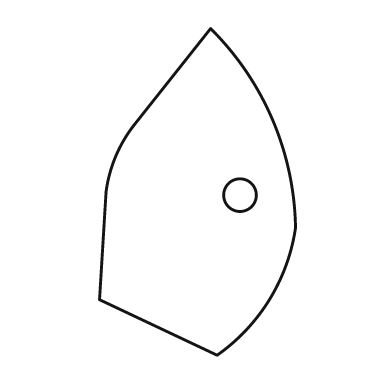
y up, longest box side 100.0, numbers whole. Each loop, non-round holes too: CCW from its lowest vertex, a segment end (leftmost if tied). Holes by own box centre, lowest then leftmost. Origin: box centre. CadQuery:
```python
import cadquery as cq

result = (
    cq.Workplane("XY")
    .moveTo(6.0, -50.0)
    .threePointArc((22.0, -33.0), (30.0, -11.0))
    .threePointArc((23.0, 22.0), (4.0, 50.0))
    .lineTo(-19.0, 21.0)
    .threePointArc((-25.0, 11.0), (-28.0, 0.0))
    .lineTo(-30.0, -33.0)
    .close()
    .moveTo(13.0, -1.0)
    .circle(5.0)
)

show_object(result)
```